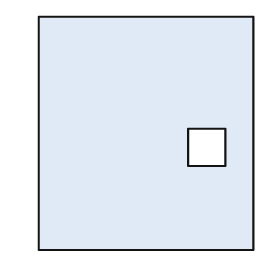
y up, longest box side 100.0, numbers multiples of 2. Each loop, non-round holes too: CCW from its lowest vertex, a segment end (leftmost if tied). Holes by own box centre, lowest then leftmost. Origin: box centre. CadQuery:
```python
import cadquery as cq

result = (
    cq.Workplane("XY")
    .moveTo(-46.0, -50.0)
    .lineTo(46.0, -50.0)
    .lineTo(46.0, 50.0)
    .lineTo(-46.0, 50.0)
    .close()
    .moveTo(18.0, -14.0)
    .lineTo(34.0, -14.0)
    .lineTo(34.0, 2.0)
    .lineTo(18.0, 2.0)
    .close()
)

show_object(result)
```